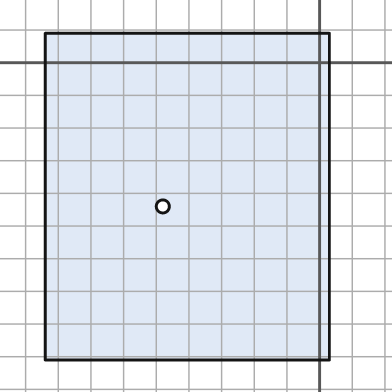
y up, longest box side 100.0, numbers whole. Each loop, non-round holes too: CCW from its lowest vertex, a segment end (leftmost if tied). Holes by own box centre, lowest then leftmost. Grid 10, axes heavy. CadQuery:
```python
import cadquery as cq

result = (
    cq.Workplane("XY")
    .moveTo(-84.0, -91.0)
    .lineTo(3.0, -91.0)
    .lineTo(3.0, 9.0)
    .lineTo(-84.0, 9.0)
    .close()
    .moveTo(-48.0, -44.0)
    .circle(2.0)
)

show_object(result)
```